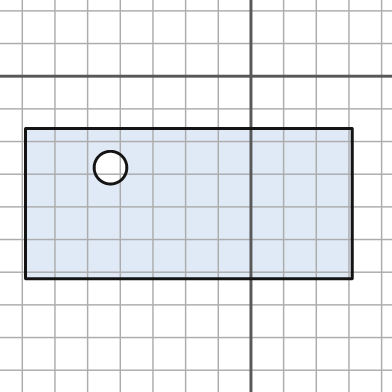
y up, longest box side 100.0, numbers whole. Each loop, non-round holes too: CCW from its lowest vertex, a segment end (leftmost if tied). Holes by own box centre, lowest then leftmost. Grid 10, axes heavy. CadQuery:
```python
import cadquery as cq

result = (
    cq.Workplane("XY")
    .moveTo(-69.0, -62.0)
    .lineTo(31.0, -62.0)
    .lineTo(31.0, -16.0)
    .lineTo(-69.0, -16.0)
    .close()
    .moveTo(-43.0, -28.0)
    .circle(5.0)
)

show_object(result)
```